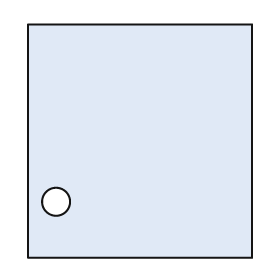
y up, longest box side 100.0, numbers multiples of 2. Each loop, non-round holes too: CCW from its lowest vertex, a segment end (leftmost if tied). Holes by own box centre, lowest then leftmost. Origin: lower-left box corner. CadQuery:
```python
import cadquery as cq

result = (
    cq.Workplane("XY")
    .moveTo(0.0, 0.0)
    .lineTo(96.0, 0.0)
    .lineTo(96.0, 100.0)
    .lineTo(0.0, 100.0)
    .close()
    .moveTo(12.0, 24.0)
    .circle(6.0)
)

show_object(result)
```